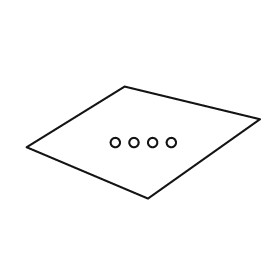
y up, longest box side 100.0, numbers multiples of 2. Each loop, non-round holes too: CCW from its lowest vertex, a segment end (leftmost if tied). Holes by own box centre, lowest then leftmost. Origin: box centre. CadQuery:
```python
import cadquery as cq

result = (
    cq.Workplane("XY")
    .moveTo(2.0, -24.0)
    .lineTo(50.0, 10.0)
    .lineTo(-8.0, 24.0)
    .lineTo(-50.0, -2.0)
    .close()
    .moveTo(-12.0, 0.0)
    .circle(2.0)
    .moveTo(-4.0, 0.0)
    .circle(2.0)
    .moveTo(4.0, 0.0)
    .circle(2.0)
    .moveTo(12.0, 0.0)
    .circle(2.0)
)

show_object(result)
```